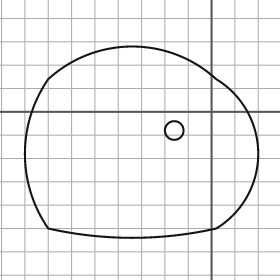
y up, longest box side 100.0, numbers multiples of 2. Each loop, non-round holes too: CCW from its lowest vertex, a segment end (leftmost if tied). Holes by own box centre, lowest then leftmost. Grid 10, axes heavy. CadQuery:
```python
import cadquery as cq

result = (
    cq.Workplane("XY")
    .moveTo(-70.0, -50.0)
    .threePointArc((-34.0, -54.0), (2.0, -50.0))
    .threePointArc((20.0, -18.0), (2.0, 14.0))
    .threePointArc((-34.0, 28.0), (-70.0, 14.0))
    .threePointArc((-80.0, -18.0), (-70.0, -50.0))
    .close()
    .moveTo(-16.0, -8.0)
    .circle(4.0)
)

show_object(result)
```